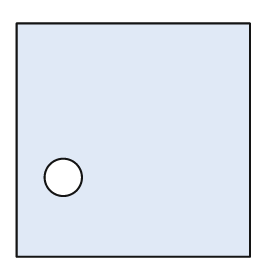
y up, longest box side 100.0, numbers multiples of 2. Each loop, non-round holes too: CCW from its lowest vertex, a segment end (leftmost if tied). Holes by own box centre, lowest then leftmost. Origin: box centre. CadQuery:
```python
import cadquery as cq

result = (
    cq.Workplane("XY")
    .moveTo(-50.0, -50.0)
    .lineTo(50.0, -50.0)
    .lineTo(50.0, 50.0)
    .lineTo(-50.0, 50.0)
    .close()
    .moveTo(-30.0, -16.0)
    .circle(8.0)
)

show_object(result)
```